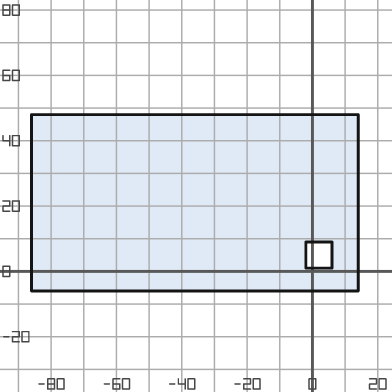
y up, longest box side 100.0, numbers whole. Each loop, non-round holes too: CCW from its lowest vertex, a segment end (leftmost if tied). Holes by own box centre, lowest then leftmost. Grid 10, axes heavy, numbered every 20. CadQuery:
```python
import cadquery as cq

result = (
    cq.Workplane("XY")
    .moveTo(-86.0, -6.0)
    .lineTo(14.0, -6.0)
    .lineTo(14.0, 48.0)
    .lineTo(-86.0, 48.0)
    .close()
    .moveTo(-2.0, 1.0)
    .lineTo(6.0, 1.0)
    .lineTo(6.0, 9.0)
    .lineTo(-2.0, 9.0)
    .close()
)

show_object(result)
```